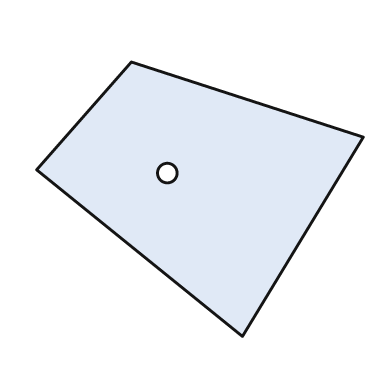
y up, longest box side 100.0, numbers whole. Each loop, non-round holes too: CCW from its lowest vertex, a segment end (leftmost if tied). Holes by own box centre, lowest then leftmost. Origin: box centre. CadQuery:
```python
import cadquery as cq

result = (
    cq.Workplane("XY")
    .moveTo(13.0, -42.0)
    .lineTo(50.0, 19.0)
    .lineTo(-21.0, 42.0)
    .lineTo(-50.0, 9.0)
    .close()
    .moveTo(-10.0, 8.0)
    .circle(3.0)
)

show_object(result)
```